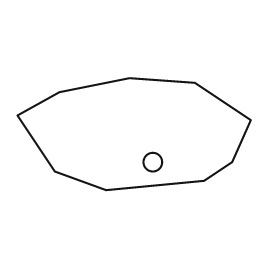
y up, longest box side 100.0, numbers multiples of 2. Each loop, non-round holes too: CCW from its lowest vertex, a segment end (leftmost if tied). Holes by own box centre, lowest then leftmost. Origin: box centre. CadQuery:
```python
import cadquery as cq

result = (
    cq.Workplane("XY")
    .moveTo(-12.0, -24.0)
    .lineTo(30.0, -20.0)
    .lineTo(42.0, -12.0)
    .lineTo(50.0, 6.0)
    .lineTo(26.0, 22.0)
    .lineTo(-2.0, 24.0)
    .lineTo(-32.0, 18.0)
    .lineTo(-50.0, 8.0)
    .lineTo(-34.0, -16.0)
    .close()
    .moveTo(8.0, -12.0)
    .circle(4.0)
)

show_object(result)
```